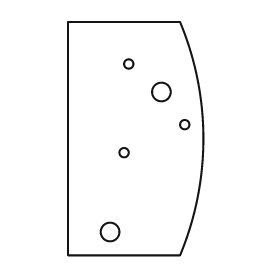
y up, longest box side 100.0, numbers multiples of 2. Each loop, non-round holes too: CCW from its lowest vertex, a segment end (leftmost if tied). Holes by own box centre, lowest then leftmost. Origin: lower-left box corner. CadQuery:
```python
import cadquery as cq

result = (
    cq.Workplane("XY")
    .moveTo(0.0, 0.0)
    .lineTo(48.0, 0.0)
    .threePointArc((58.0, 50.0), (48.0, 100.0))
    .lineTo(0.0, 100.0)
    .close()
    .moveTo(18.0, 10.0)
    .circle(4.0)
    .moveTo(24.0, 44.0)
    .circle(2.0)
    .moveTo(50.0, 56.0)
    .circle(2.0)
    .moveTo(40.0, 70.0)
    .circle(4.0)
    .moveTo(26.0, 82.0)
    .circle(2.0)
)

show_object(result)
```